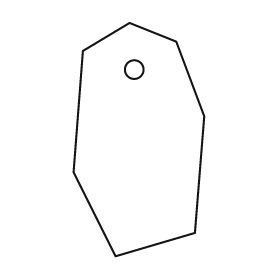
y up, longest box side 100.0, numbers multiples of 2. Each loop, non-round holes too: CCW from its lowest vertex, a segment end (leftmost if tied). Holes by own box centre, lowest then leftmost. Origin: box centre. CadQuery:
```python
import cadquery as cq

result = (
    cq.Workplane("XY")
    .moveTo(-10.0, -50.0)
    .lineTo(24.0, -40.0)
    .lineTo(28.0, 10.0)
    .lineTo(16.0, 42.0)
    .lineTo(-4.0, 50.0)
    .lineTo(-24.0, 38.0)
    .lineTo(-28.0, -14.0)
    .close()
    .moveTo(-2.0, 30.0)
    .circle(4.0)
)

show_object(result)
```